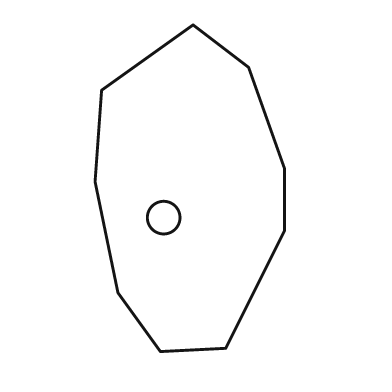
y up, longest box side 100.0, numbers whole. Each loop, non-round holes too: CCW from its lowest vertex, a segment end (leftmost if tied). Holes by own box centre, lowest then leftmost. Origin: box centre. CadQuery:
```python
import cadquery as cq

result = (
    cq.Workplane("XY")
    .moveTo(-9.0, -50.0)
    .lineTo(11.0, -49.0)
    .lineTo(29.0, -13.0)
    .lineTo(29.0, 6.0)
    .lineTo(18.0, 37.0)
    .lineTo(1.0, 50.0)
    .lineTo(-27.0, 30.0)
    .lineTo(-29.0, 2.0)
    .lineTo(-22.0, -32.0)
    .close()
    .moveTo(-8.0, -9.0)
    .circle(5.0)
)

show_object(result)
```